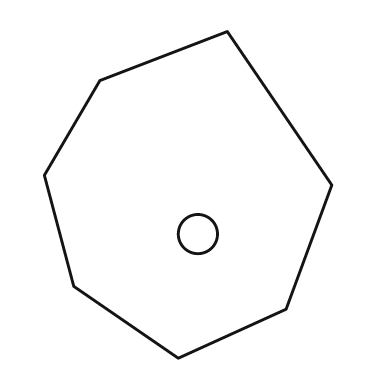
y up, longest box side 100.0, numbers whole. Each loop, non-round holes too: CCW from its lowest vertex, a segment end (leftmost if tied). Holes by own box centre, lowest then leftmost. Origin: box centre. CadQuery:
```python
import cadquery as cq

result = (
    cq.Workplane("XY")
    .moveTo(-3.0, -50.0)
    .lineTo(30.0, -35.0)
    .lineTo(44.0, 3.0)
    .lineTo(12.0, 50.0)
    .lineTo(-27.0, 35.0)
    .lineTo(-44.0, 6.0)
    .lineTo(-35.0, -28.0)
    .close()
    .moveTo(3.0, -12.0)
    .circle(6.0)
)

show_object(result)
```